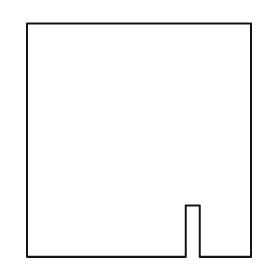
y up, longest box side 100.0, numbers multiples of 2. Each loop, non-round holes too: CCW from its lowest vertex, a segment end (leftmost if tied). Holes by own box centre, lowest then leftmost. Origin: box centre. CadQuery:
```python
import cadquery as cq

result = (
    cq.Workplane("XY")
    .moveTo(-48.0, -50.0)
    .lineTo(20.0, -50.0)
    .lineTo(20.0, -28.0)
    .lineTo(26.0, -28.0)
    .lineTo(26.0, -50.0)
    .lineTo(48.0, -50.0)
    .lineTo(48.0, 50.0)
    .lineTo(-48.0, 50.0)
    .close()
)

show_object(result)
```